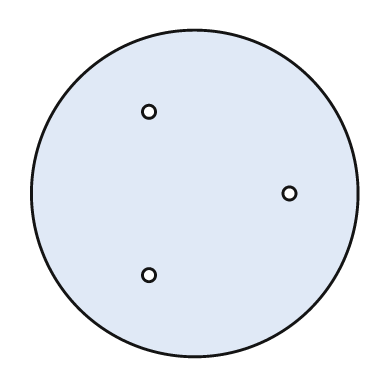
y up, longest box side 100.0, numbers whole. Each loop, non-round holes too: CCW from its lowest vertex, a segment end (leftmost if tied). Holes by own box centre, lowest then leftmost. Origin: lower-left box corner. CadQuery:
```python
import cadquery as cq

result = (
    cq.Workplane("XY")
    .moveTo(50.0, 50.0)
    .circle(50.0)
    .moveTo(36.0, 25.0)
    .circle(2.0)
    .moveTo(79.0, 50.0)
    .circle(2.0)
    .moveTo(36.0, 75.0)
    .circle(2.0)
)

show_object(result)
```